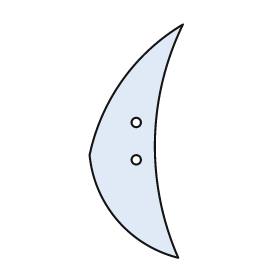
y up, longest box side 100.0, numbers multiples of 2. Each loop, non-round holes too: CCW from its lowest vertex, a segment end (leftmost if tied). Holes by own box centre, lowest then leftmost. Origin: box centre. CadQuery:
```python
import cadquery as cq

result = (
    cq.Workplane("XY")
    .moveTo(18.0, -50.0)
    .threePointArc((8.0, 0.0), (20.0, 50.0))
    .threePointArc((-6.0, 26.0), (-20.0, -6.0))
    .threePointArc((-8.0, -34.0), (18.0, -50.0))
    .close()
    .moveTo(0.0, -8.0)
    .circle(2.0)
    .moveTo(0.0, 8.0)
    .circle(2.0)
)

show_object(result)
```